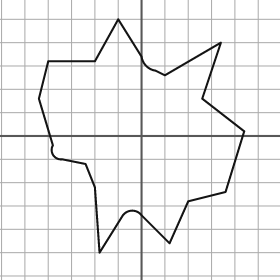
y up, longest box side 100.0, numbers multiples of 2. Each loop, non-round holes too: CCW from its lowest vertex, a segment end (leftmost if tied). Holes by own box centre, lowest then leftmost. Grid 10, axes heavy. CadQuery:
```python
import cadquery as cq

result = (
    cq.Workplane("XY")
    .moveTo(-18.0, -50.0)
    .lineTo(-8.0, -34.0)
    .threePointArc((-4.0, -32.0), (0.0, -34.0))
    .lineTo(12.0, -46.0)
    .lineTo(20.0, -28.0)
    .lineTo(36.0, -24.0)
    .lineTo(44.0, 2.0)
    .lineTo(26.0, 16.0)
    .lineTo(34.0, 40.0)
    .lineTo(10.0, 26.0)
    .lineTo(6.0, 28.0)
    .threePointArc((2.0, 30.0), (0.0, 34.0))
    .lineTo(-10.0, 50.0)
    .lineTo(-20.0, 32.0)
    .lineTo(-40.0, 32.0)
    .lineTo(-44.0, 16.0)
    .lineTo(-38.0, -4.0)
    .threePointArc((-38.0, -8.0), (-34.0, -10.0))
    .lineTo(-24.0, -12.0)
    .lineTo(-20.0, -22.0)
    .close()
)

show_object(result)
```